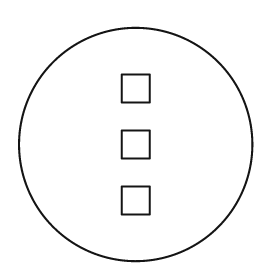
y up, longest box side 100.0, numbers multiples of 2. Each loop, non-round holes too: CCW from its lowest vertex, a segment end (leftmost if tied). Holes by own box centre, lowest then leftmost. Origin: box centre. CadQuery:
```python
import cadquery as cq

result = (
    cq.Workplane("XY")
    .moveTo(0.0, 0.0)
    .circle(50.0)
    .moveTo(-6.0, -30.0)
    .lineTo(6.0, -30.0)
    .lineTo(6.0, -18.0)
    .lineTo(-6.0, -18.0)
    .close()
    .moveTo(-6.0, -6.0)
    .lineTo(6.0, -6.0)
    .lineTo(6.0, 6.0)
    .lineTo(-6.0, 6.0)
    .close()
    .moveTo(-6.0, 18.0)
    .lineTo(6.0, 18.0)
    .lineTo(6.0, 30.0)
    .lineTo(-6.0, 30.0)
    .close()
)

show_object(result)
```